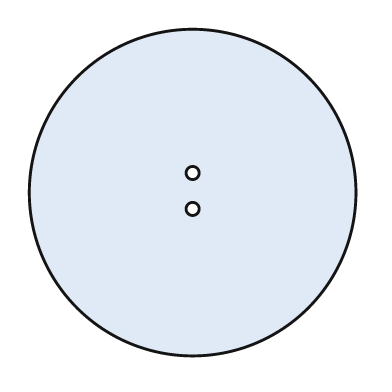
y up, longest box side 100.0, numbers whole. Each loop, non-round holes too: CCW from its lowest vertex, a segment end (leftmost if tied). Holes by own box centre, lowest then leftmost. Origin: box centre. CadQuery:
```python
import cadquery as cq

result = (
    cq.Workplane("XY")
    .moveTo(0.0, 0.0)
    .circle(50.0)
    .moveTo(0.0, -5.0)
    .circle(2.0)
    .moveTo(0.0, 6.0)
    .circle(2.0)
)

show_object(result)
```